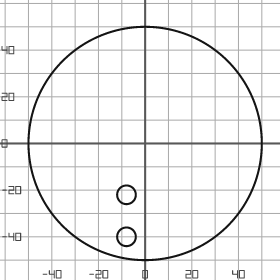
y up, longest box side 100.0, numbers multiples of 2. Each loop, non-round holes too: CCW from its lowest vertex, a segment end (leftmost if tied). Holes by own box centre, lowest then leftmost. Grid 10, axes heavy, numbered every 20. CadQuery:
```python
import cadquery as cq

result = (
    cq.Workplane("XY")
    .moveTo(0.0, 0.0)
    .circle(50.0)
    .moveTo(-8.0, -40.0)
    .circle(4.0)
    .moveTo(-8.0, -22.0)
    .circle(4.0)
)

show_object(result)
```